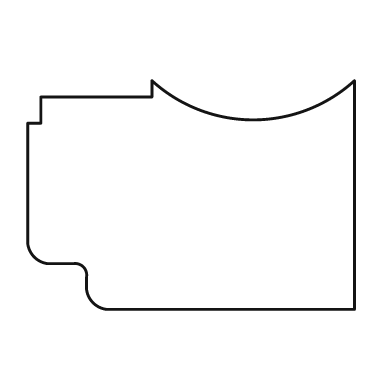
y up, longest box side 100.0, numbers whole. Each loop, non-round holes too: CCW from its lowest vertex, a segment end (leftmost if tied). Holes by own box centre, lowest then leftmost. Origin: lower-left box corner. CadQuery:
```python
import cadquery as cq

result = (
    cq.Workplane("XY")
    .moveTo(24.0, 0.0)
    .lineTo(100.0, 0.0)
    .lineTo(100.0, 70.0)
    .threePointArc((69.0, 58.0), (38.0, 70.0))
    .lineTo(38.0, 65.0)
    .lineTo(4.0, 65.0)
    .lineTo(4.0, 57.0)
    .lineTo(0.0, 57.0)
    .lineTo(0.0, 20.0)
    .threePointArc((2.0, 16.0), (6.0, 14.0))
    .lineTo(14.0, 14.0)
    .threePointArc((17.0, 13.0), (18.0, 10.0))
    .lineTo(18.0, 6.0)
    .threePointArc((20.0, 2.0), (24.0, 0.0))
    .close()
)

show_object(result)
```